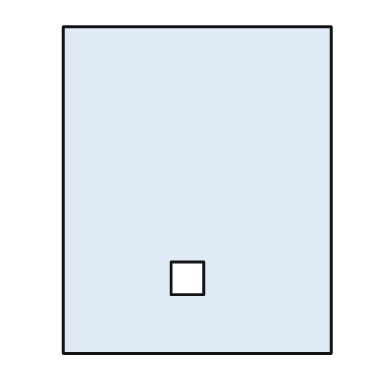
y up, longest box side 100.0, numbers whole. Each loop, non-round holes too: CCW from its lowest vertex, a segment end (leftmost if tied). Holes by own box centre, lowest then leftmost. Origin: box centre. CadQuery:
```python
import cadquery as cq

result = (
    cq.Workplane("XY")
    .moveTo(-41.0, -50.0)
    .lineTo(41.0, -50.0)
    .lineTo(41.0, 50.0)
    .lineTo(-41.0, 50.0)
    .close()
    .moveTo(-8.0, -32.0)
    .lineTo(2.0, -32.0)
    .lineTo(2.0, -22.0)
    .lineTo(-8.0, -22.0)
    .close()
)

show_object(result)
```